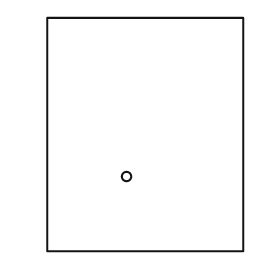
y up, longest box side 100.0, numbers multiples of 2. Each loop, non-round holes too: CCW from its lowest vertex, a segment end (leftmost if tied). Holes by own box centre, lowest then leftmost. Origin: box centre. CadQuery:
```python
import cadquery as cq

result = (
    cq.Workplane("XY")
    .moveTo(-42.0, -50.0)
    .lineTo(42.0, -50.0)
    .lineTo(42.0, 50.0)
    .lineTo(-42.0, 50.0)
    .close()
    .moveTo(-8.0, -18.0)
    .circle(2.0)
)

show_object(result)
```